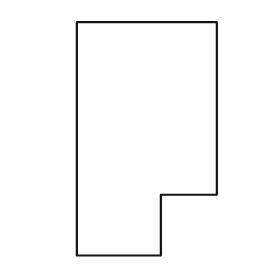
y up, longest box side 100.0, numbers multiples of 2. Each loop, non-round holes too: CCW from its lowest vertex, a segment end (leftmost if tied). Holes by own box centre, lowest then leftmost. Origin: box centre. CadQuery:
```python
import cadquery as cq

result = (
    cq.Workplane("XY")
    .moveTo(-30.0, -50.0)
    .lineTo(6.0, -50.0)
    .lineTo(6.0, -24.0)
    .lineTo(30.0, -24.0)
    .lineTo(30.0, 50.0)
    .lineTo(-30.0, 50.0)
    .close()
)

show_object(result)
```